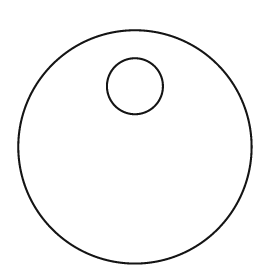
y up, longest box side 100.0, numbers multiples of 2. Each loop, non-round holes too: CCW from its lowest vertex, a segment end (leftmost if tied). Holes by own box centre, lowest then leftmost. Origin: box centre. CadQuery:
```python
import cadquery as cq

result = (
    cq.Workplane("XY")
    .moveTo(0.0, 0.0)
    .circle(50.0)
    .moveTo(0.0, 26.0)
    .circle(12.0)
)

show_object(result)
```